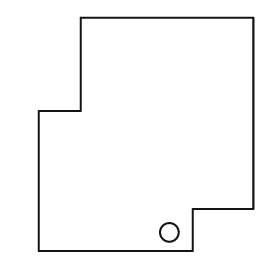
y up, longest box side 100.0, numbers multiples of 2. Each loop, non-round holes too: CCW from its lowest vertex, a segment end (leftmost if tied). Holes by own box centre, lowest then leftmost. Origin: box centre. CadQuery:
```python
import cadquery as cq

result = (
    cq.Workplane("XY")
    .moveTo(-46.0, -50.0)
    .lineTo(20.0, -50.0)
    .lineTo(20.0, -32.0)
    .lineTo(46.0, -32.0)
    .lineTo(46.0, 50.0)
    .lineTo(-28.0, 50.0)
    .lineTo(-28.0, 10.0)
    .lineTo(-46.0, 10.0)
    .close()
    .moveTo(10.0, -42.0)
    .circle(4.0)
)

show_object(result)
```